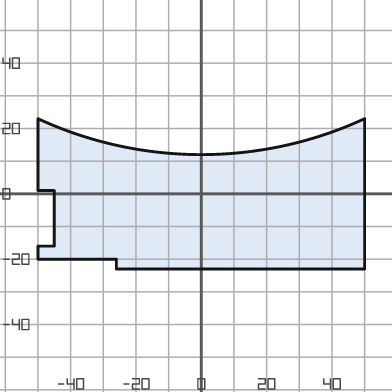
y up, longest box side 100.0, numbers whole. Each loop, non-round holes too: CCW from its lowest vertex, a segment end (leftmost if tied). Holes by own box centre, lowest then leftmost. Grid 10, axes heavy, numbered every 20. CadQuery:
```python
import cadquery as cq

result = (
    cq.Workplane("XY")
    .moveTo(-26.0, -23.0)
    .lineTo(50.0, -23.0)
    .lineTo(50.0, 23.0)
    .threePointArc((0.0, 12.0), (-50.0, 23.0))
    .lineTo(-50.0, 1.0)
    .lineTo(-45.0, 1.0)
    .lineTo(-45.0, -16.0)
    .lineTo(-50.0, -16.0)
    .lineTo(-50.0, -20.0)
    .lineTo(-26.0, -20.0)
    .close()
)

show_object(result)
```